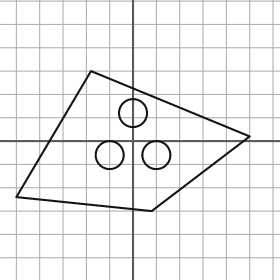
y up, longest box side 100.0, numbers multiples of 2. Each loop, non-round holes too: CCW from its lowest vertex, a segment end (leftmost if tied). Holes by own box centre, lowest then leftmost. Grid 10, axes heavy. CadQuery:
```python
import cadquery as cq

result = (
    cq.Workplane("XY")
    .moveTo(8.0, -30.0)
    .lineTo(50.0, 2.0)
    .lineTo(-18.0, 30.0)
    .lineTo(-50.0, -24.0)
    .close()
    .moveTo(-10.0, -6.0)
    .circle(6.0)
    .moveTo(10.0, -6.0)
    .circle(6.0)
    .moveTo(0.0, 12.0)
    .circle(6.0)
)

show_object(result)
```